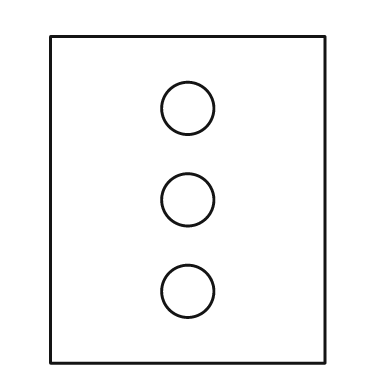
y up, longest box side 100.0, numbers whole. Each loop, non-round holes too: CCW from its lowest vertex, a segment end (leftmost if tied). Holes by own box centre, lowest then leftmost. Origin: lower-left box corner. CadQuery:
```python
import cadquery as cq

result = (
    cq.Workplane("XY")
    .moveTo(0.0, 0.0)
    .lineTo(84.0, 0.0)
    .lineTo(84.0, 100.0)
    .lineTo(0.0, 100.0)
    .close()
    .moveTo(42.0, 22.0)
    .circle(8.0)
    .moveTo(42.0, 50.0)
    .circle(8.0)
    .moveTo(42.0, 78.0)
    .circle(8.0)
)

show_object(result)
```